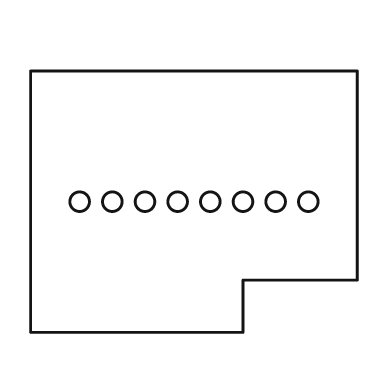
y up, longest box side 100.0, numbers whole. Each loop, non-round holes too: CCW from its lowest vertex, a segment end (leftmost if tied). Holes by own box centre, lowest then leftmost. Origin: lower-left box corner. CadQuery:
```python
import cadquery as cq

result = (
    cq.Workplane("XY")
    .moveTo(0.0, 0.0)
    .lineTo(65.0, 0.0)
    .lineTo(65.0, 16.0)
    .lineTo(100.0, 16.0)
    .lineTo(100.0, 80.0)
    .lineTo(0.0, 80.0)
    .close()
    .moveTo(15.0, 40.0)
    .circle(3.0)
    .moveTo(25.0, 40.0)
    .circle(3.0)
    .moveTo(35.0, 40.0)
    .circle(3.0)
    .moveTo(45.0, 40.0)
    .circle(3.0)
    .moveTo(55.0, 40.0)
    .circle(3.0)
    .moveTo(65.0, 40.0)
    .circle(3.0)
    .moveTo(75.0, 40.0)
    .circle(3.0)
    .moveTo(85.0, 40.0)
    .circle(3.0)
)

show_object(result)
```